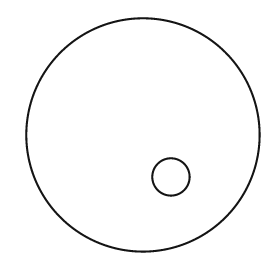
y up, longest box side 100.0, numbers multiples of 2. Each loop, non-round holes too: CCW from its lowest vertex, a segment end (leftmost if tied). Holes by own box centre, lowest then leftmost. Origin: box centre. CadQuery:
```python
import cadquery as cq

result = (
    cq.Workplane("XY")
    .moveTo(0.0, 0.0)
    .circle(50.0)
    .moveTo(12.0, -18.0)
    .circle(8.0)
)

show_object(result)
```